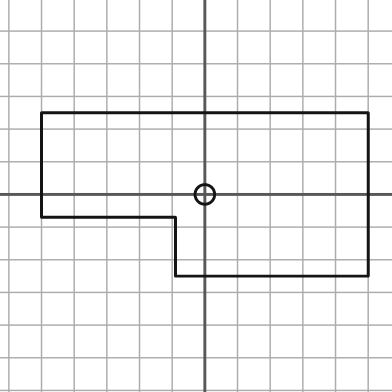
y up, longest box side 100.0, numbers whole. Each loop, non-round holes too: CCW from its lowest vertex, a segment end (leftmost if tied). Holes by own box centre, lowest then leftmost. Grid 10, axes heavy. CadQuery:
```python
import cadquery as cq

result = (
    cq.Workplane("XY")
    .moveTo(-9.0, -25.0)
    .lineTo(50.0, -25.0)
    .lineTo(50.0, 25.0)
    .lineTo(-50.0, 25.0)
    .lineTo(-50.0, -7.0)
    .lineTo(-9.0, -7.0)
    .close()
    .moveTo(0.0, 0.0)
    .circle(3.0)
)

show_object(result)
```